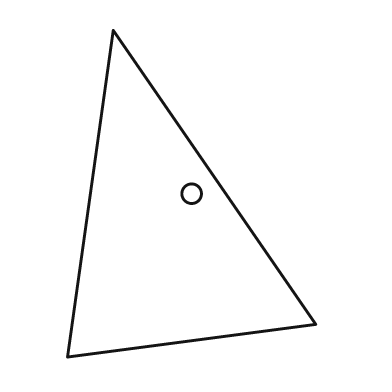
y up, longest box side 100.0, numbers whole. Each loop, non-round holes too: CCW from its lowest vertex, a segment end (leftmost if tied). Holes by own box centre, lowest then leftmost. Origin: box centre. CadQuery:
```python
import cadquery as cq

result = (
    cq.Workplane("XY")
    .moveTo(-38.0, -50.0)
    .lineTo(38.0, -40.0)
    .lineTo(-24.0, 50.0)
    .close()
    .moveTo(0.0, 0.0)
    .circle(3.0)
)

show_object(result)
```